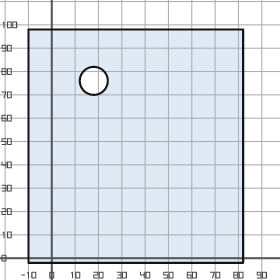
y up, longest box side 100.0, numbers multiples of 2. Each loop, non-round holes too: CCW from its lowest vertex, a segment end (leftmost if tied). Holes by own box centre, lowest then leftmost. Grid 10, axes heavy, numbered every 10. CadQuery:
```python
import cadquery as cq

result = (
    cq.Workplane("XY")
    .moveTo(-10.0, -2.0)
    .lineTo(82.0, -2.0)
    .lineTo(82.0, 98.0)
    .lineTo(-10.0, 98.0)
    .close()
    .moveTo(18.0, 76.0)
    .circle(6.0)
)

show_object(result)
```